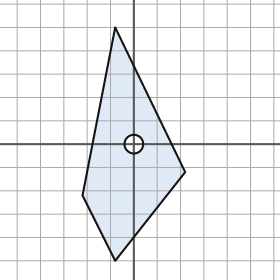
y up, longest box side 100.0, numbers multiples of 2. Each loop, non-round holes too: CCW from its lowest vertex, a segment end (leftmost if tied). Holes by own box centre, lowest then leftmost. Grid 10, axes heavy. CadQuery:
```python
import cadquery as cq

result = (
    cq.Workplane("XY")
    .moveTo(-8.0, -50.0)
    .lineTo(22.0, -12.0)
    .lineTo(-8.0, 50.0)
    .lineTo(-22.0, -22.0)
    .close()
    .moveTo(0.0, 0.0)
    .circle(4.0)
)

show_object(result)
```